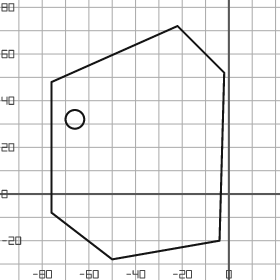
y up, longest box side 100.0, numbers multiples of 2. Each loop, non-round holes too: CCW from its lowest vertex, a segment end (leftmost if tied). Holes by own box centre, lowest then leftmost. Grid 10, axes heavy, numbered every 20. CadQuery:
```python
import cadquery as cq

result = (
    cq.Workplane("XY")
    .moveTo(-50.0, -28.0)
    .lineTo(-4.0, -20.0)
    .lineTo(-2.0, 52.0)
    .lineTo(-22.0, 72.0)
    .lineTo(-76.0, 48.0)
    .lineTo(-76.0, -8.0)
    .close()
    .moveTo(-66.0, 32.0)
    .circle(4.0)
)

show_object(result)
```